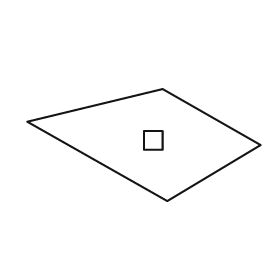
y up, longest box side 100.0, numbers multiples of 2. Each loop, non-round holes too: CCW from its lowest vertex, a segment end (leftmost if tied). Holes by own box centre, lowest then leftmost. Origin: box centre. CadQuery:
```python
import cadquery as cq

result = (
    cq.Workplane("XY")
    .moveTo(10.0, -24.0)
    .lineTo(50.0, 0.0)
    .lineTo(8.0, 24.0)
    .lineTo(-50.0, 10.0)
    .close()
    .moveTo(0.0, -2.0)
    .lineTo(8.0, -2.0)
    .lineTo(8.0, 6.0)
    .lineTo(0.0, 6.0)
    .close()
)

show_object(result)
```